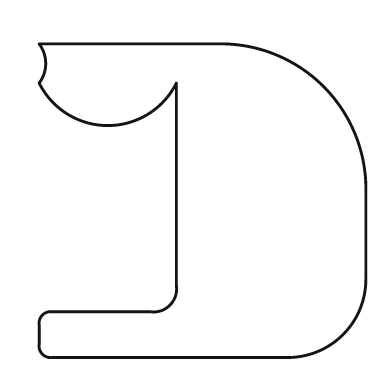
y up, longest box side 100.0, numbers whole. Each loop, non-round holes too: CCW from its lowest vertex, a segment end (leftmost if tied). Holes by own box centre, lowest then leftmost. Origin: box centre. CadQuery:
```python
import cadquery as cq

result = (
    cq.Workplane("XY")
    .moveTo(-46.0, -48.0)
    .lineTo(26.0, -48.0)
    .threePointArc((43.0, -41.0), (50.0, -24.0))
    .lineTo(50.0, 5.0)
    .threePointArc((37.0, 35.0), (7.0, 48.0))
    .lineTo(-50.0, 48.0)
    .threePointArc((-48.0, 42.0), (-50.0, 36.0))
    .threePointArc((-29.0, 23.0), (-8.0, 36.0))
    .lineTo(-8.0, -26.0)
    .threePointArc((-10.0, -32.0), (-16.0, -34.0))
    .lineTo(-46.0, -34.0)
    .threePointArc((-49.0, -35.0), (-50.0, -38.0))
    .lineTo(-50.0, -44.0)
    .threePointArc((-49.0, -47.0), (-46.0, -48.0))
    .close()
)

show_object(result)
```